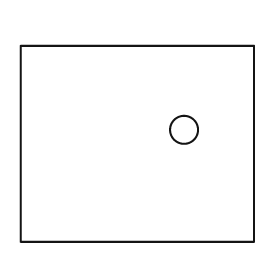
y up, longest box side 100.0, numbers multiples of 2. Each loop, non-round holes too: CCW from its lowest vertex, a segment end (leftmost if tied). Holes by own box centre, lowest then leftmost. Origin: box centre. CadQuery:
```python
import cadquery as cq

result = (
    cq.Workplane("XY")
    .moveTo(-50.0, -42.0)
    .lineTo(50.0, -42.0)
    .lineTo(50.0, 42.0)
    .lineTo(-50.0, 42.0)
    .close()
    .moveTo(20.0, 6.0)
    .circle(6.0)
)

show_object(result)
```